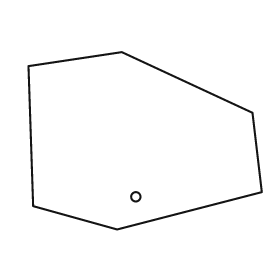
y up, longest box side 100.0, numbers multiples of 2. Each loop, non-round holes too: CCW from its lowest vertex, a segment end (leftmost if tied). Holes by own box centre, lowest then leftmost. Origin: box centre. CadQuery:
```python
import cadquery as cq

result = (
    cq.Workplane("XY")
    .moveTo(-12.0, -38.0)
    .lineTo(50.0, -22.0)
    .lineTo(46.0, 12.0)
    .lineTo(-10.0, 38.0)
    .lineTo(-50.0, 32.0)
    .lineTo(-48.0, -28.0)
    .close()
    .moveTo(-4.0, -24.0)
    .circle(2.0)
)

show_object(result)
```